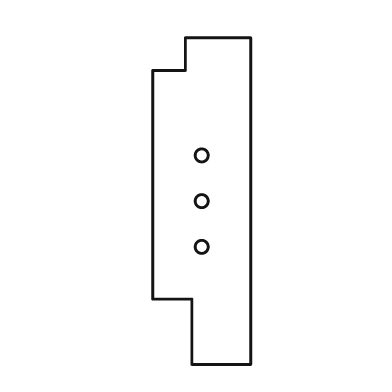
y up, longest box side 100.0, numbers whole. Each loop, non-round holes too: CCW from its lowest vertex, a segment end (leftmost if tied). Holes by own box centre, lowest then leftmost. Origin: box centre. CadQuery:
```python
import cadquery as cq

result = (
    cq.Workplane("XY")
    .moveTo(-3.0, -50.0)
    .lineTo(15.0, -50.0)
    .lineTo(15.0, 50.0)
    .lineTo(-5.0, 50.0)
    .lineTo(-5.0, 40.0)
    .lineTo(-15.0, 40.0)
    .lineTo(-15.0, -30.0)
    .lineTo(-3.0, -30.0)
    .close()
    .moveTo(0.0, -14.0)
    .circle(2.0)
    .moveTo(0.0, 0.0)
    .circle(2.0)
    .moveTo(0.0, 14.0)
    .circle(2.0)
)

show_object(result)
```